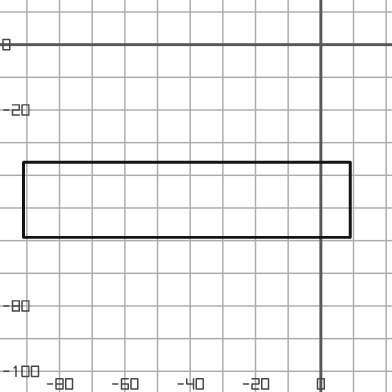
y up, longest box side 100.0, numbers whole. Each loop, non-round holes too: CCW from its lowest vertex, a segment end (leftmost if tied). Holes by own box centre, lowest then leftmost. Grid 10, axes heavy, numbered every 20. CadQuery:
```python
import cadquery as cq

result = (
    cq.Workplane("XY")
    .moveTo(-91.0, -59.0)
    .lineTo(9.0, -59.0)
    .lineTo(9.0, -36.0)
    .lineTo(-91.0, -36.0)
    .close()
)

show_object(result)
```